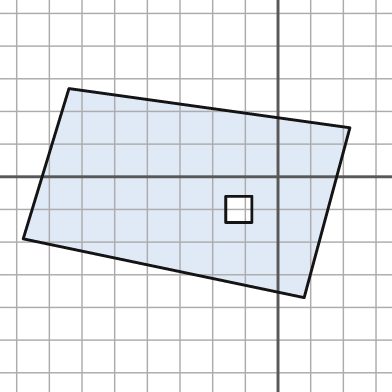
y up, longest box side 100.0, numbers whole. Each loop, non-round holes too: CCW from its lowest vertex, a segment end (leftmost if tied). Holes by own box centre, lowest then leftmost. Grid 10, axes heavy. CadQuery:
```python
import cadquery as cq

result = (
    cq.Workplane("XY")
    .moveTo(8.0, -37.0)
    .lineTo(22.0, 15.0)
    .lineTo(-64.0, 27.0)
    .lineTo(-78.0, -19.0)
    .close()
    .moveTo(-16.0, -14.0)
    .lineTo(-8.0, -14.0)
    .lineTo(-8.0, -6.0)
    .lineTo(-16.0, -6.0)
    .close()
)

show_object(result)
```